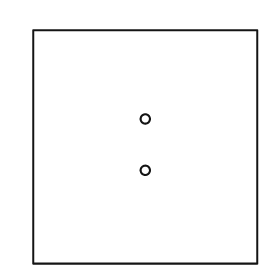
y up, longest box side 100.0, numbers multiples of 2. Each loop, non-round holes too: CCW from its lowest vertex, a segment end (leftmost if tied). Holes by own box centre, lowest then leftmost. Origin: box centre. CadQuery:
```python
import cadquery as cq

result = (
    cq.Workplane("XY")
    .moveTo(-48.0, -50.0)
    .lineTo(48.0, -50.0)
    .lineTo(48.0, 50.0)
    .lineTo(-48.0, 50.0)
    .close()
    .moveTo(0.0, -10.0)
    .circle(2.0)
    .moveTo(0.0, 12.0)
    .circle(2.0)
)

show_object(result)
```